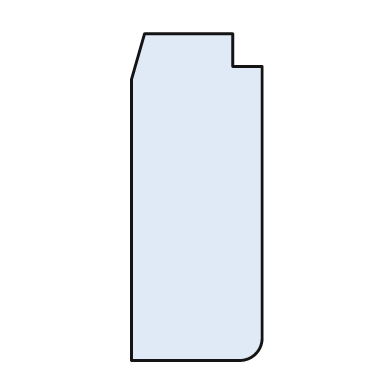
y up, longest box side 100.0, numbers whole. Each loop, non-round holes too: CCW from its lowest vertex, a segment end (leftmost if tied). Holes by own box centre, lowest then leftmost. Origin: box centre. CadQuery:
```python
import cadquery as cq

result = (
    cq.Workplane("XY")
    .moveTo(-20.0, -50.0)
    .lineTo(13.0, -50.0)
    .threePointArc((18.0, -48.0), (20.0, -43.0))
    .lineTo(20.0, 40.0)
    .lineTo(11.0, 40.0)
    .lineTo(11.0, 50.0)
    .lineTo(-16.0, 50.0)
    .lineTo(-20.0, 36.0)
    .close()
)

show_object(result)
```